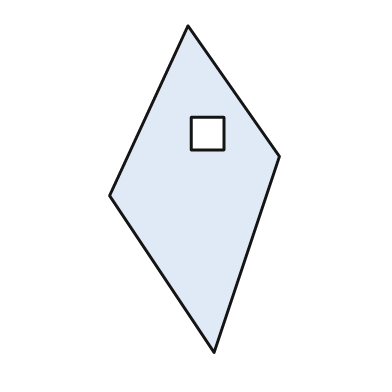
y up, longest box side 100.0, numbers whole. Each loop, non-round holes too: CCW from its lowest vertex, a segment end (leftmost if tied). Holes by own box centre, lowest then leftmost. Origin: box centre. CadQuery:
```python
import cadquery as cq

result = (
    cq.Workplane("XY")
    .moveTo(6.0, -50.0)
    .lineTo(26.0, 10.0)
    .lineTo(-2.0, 50.0)
    .lineTo(-26.0, -2.0)
    .close()
    .moveTo(-1.0, 12.0)
    .lineTo(9.0, 12.0)
    .lineTo(9.0, 22.0)
    .lineTo(-1.0, 22.0)
    .close()
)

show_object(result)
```